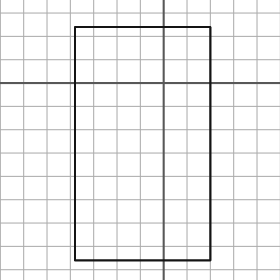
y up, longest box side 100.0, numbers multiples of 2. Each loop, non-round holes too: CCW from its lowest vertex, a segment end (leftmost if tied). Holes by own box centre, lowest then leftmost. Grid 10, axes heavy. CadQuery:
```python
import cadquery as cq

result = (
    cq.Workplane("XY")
    .moveTo(-38.0, -76.0)
    .lineTo(20.0, -76.0)
    .lineTo(20.0, 24.0)
    .lineTo(-38.0, 24.0)
    .close()
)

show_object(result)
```